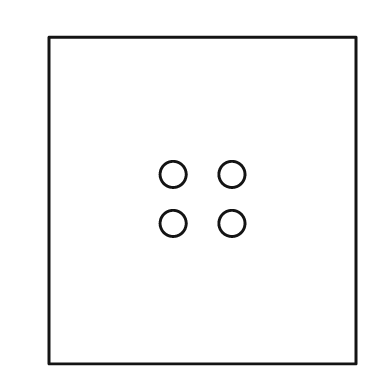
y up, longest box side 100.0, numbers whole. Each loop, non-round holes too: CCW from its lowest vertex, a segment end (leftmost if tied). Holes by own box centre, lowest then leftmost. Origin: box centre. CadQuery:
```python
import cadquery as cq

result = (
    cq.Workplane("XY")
    .moveTo(-47.0, -50.0)
    .lineTo(47.0, -50.0)
    .lineTo(47.0, 50.0)
    .lineTo(-47.0, 50.0)
    .close()
    .moveTo(-9.0, -7.0)
    .circle(4.0)
    .moveTo(9.0, -7.0)
    .circle(4.0)
    .moveTo(-9.0, 8.0)
    .circle(4.0)
    .moveTo(9.0, 8.0)
    .circle(4.0)
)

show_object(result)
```